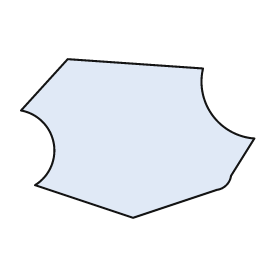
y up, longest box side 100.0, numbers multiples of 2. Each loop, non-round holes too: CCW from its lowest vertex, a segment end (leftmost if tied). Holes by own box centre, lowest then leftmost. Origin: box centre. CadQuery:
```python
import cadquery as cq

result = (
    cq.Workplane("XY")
    .moveTo(-2.0, -34.0)
    .lineTo(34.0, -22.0)
    .threePointArc((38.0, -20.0), (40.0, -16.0))
    .lineTo(50.0, 0.0)
    .threePointArc((32.0, 10.0), (28.0, 30.0))
    .lineTo(-30.0, 34.0)
    .lineTo(-50.0, 12.0)
    .threePointArc((-36.0, -2.0), (-44.0, -20.0))
    .close()
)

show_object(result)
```